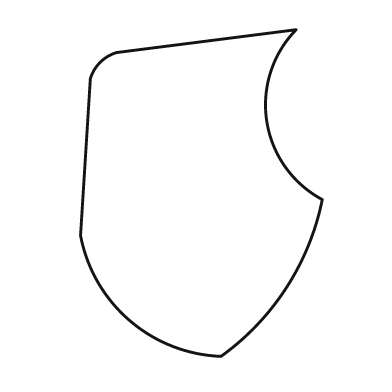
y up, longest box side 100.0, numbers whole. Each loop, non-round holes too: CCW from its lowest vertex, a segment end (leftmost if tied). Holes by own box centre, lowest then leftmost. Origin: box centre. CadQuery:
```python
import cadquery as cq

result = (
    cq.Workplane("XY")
    .moveTo(6.0, -50.0)
    .threePointArc((26.0, -29.0), (37.0, -2.0))
    .threePointArc((20.0, 22.0), (29.0, 50.0))
    .lineTo(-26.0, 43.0)
    .threePointArc((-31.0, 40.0), (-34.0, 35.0))
    .lineTo(-37.0, -13.0)
    .threePointArc((-22.0, -39.0), (6.0, -50.0))
    .close()
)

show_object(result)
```